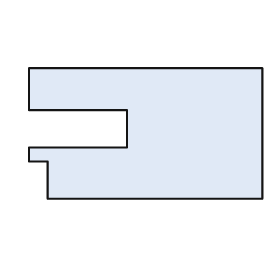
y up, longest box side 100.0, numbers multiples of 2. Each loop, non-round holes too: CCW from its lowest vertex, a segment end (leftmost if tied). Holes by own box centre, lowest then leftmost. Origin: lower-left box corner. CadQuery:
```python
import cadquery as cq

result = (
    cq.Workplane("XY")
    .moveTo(8.0, 0.0)
    .lineTo(100.0, 0.0)
    .lineTo(100.0, 56.0)
    .lineTo(0.0, 56.0)
    .lineTo(0.0, 38.0)
    .lineTo(42.0, 38.0)
    .lineTo(42.0, 22.0)
    .lineTo(0.0, 22.0)
    .lineTo(0.0, 16.0)
    .lineTo(8.0, 16.0)
    .close()
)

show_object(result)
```